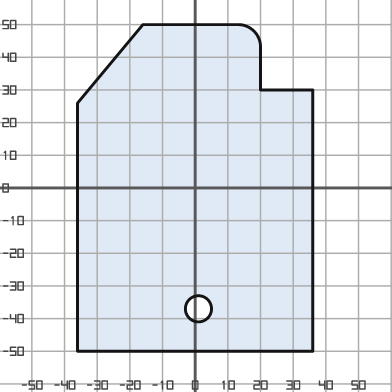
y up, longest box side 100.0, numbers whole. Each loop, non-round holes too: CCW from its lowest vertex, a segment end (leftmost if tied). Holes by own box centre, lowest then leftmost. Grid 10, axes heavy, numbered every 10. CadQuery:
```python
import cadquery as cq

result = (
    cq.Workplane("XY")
    .moveTo(-36.0, -50.0)
    .lineTo(36.0, -50.0)
    .lineTo(36.0, 30.0)
    .lineTo(20.0, 30.0)
    .lineTo(20.0, 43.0)
    .threePointArc((18.0, 48.0), (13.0, 50.0))
    .lineTo(-16.0, 50.0)
    .lineTo(-36.0, 26.0)
    .close()
    .moveTo(1.0, -37.0)
    .circle(4.0)
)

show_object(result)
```